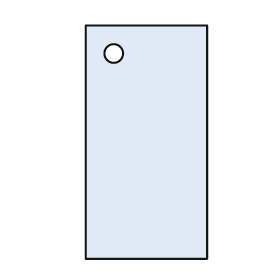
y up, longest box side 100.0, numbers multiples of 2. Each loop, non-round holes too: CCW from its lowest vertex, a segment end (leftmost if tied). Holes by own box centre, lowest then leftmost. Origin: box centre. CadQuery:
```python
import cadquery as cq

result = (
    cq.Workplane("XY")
    .moveTo(-26.0, -50.0)
    .lineTo(26.0, -50.0)
    .lineTo(26.0, 50.0)
    .lineTo(-26.0, 50.0)
    .close()
    .moveTo(-14.0, 38.0)
    .circle(4.0)
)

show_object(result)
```